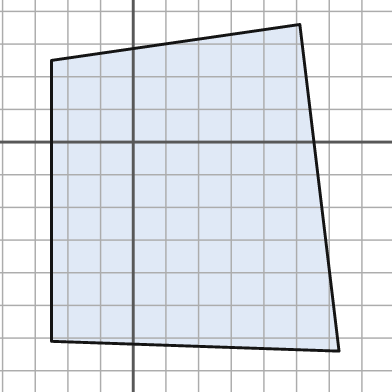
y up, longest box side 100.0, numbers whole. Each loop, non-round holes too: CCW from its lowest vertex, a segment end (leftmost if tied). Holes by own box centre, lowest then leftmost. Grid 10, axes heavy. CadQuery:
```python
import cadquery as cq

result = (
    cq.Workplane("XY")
    .moveTo(63.0, -64.0)
    .lineTo(51.0, 36.0)
    .lineTo(-25.0, 25.0)
    .lineTo(-25.0, -61.0)
    .close()
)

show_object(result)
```